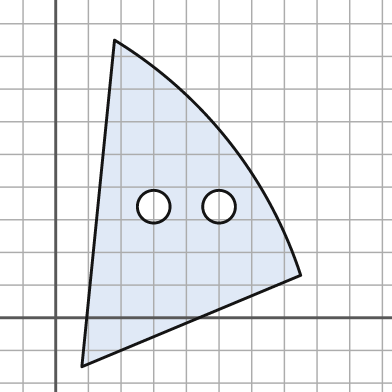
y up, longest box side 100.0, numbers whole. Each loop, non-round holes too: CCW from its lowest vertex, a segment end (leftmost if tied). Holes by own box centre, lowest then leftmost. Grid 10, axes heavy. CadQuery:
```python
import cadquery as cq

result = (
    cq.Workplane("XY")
    .moveTo(8.0, -15.0)
    .lineTo(75.0, 13.0)
    .threePointArc((53.0, 54.0), (18.0, 85.0))
    .close()
    .moveTo(30.0, 34.0)
    .circle(5.0)
    .moveTo(50.0, 34.0)
    .circle(5.0)
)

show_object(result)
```